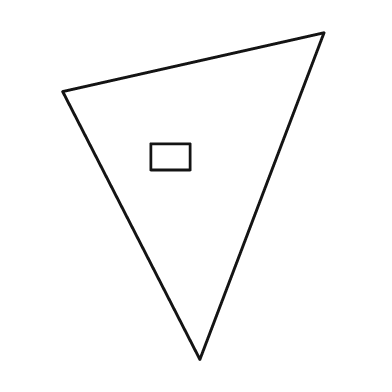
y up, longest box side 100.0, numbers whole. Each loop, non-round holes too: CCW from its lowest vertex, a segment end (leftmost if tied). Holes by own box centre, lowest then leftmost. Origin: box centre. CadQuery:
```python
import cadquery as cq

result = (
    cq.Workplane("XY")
    .moveTo(2.0, -50.0)
    .lineTo(40.0, 50.0)
    .lineTo(-40.0, 32.0)
    .close()
    .moveTo(-13.0, 8.0)
    .lineTo(-1.0, 8.0)
    .lineTo(-1.0, 16.0)
    .lineTo(-13.0, 16.0)
    .close()
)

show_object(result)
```